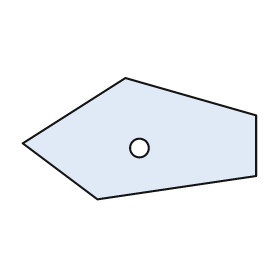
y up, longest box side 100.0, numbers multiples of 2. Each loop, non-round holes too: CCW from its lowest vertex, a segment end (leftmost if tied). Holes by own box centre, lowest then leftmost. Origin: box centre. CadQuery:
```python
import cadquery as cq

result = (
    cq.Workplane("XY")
    .moveTo(-18.0, -26.0)
    .lineTo(50.0, -16.0)
    .lineTo(50.0, 10.0)
    .lineTo(-6.0, 26.0)
    .lineTo(-50.0, -2.0)
    .close()
    .moveTo(0.0, -4.0)
    .circle(4.0)
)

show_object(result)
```